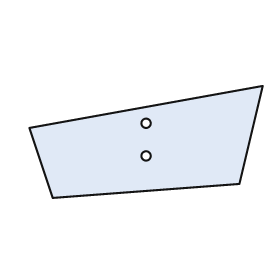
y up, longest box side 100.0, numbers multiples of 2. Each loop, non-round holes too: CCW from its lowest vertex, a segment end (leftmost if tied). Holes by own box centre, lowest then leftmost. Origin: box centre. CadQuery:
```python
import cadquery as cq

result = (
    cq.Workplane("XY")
    .moveTo(-40.0, -24.0)
    .lineTo(40.0, -18.0)
    .lineTo(50.0, 24.0)
    .lineTo(-50.0, 6.0)
    .close()
    .moveTo(0.0, -6.0)
    .circle(2.0)
    .moveTo(0.0, 8.0)
    .circle(2.0)
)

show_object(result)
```